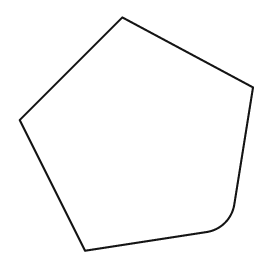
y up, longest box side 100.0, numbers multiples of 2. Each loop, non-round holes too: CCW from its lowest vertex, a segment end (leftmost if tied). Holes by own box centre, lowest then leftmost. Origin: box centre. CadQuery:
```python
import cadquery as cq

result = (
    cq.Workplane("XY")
    .moveTo(-22.0, -50.0)
    .lineTo(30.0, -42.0)
    .threePointArc((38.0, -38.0), (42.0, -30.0))
    .lineTo(50.0, 20.0)
    .lineTo(-6.0, 50.0)
    .lineTo(-50.0, 6.0)
    .close()
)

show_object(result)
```